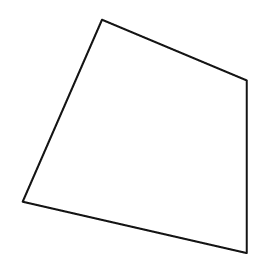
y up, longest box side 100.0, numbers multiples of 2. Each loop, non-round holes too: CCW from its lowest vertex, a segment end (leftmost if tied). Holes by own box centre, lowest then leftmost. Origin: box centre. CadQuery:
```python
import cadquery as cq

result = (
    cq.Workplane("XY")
    .moveTo(48.0, -50.0)
    .lineTo(48.0, 24.0)
    .lineTo(-14.0, 50.0)
    .lineTo(-48.0, -28.0)
    .close()
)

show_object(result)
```